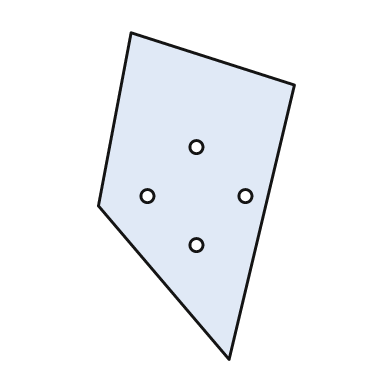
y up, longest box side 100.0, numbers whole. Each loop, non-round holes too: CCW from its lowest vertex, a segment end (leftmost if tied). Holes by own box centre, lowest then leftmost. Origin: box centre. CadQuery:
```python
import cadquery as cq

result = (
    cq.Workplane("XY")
    .moveTo(10.0, -50.0)
    .lineTo(30.0, 34.0)
    .lineTo(-20.0, 50.0)
    .lineTo(-30.0, -3.0)
    .close()
    .moveTo(0.0, -15.0)
    .circle(2.0)
    .moveTo(-15.0, 0.0)
    .circle(2.0)
    .moveTo(15.0, 0.0)
    .circle(2.0)
    .moveTo(0.0, 15.0)
    .circle(2.0)
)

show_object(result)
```